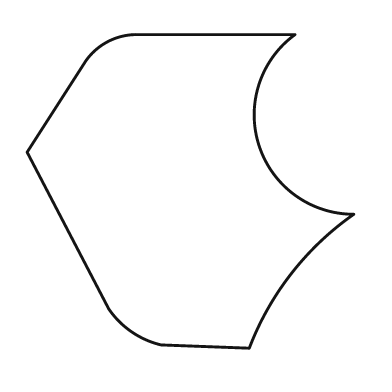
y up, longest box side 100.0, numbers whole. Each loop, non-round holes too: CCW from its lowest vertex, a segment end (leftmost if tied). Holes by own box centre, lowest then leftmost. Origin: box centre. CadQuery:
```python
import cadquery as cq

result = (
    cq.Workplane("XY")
    .moveTo(18.0, -48.0)
    .threePointArc((31.0, -25.0), (50.0, -7.0))
    .threePointArc((21.0, 14.0), (32.0, 48.0))
    .lineTo(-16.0, 48.0)
    .threePointArc((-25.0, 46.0), (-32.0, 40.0))
    .lineTo(-50.0, 12.0)
    .lineTo(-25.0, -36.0)
    .threePointArc((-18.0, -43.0), (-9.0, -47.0))
    .close()
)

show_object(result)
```